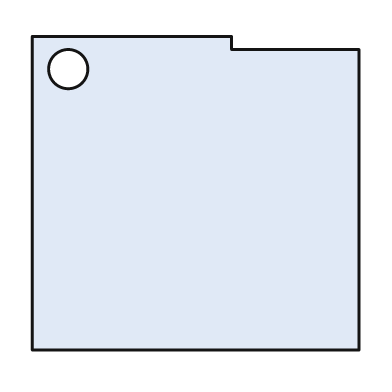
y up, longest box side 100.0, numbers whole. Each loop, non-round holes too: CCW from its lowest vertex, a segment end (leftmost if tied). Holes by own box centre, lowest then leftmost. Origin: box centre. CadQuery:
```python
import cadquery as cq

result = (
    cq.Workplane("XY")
    .moveTo(-50.0, -48.0)
    .lineTo(50.0, -48.0)
    .lineTo(50.0, 44.0)
    .lineTo(11.0, 44.0)
    .lineTo(11.0, 48.0)
    .lineTo(-50.0, 48.0)
    .close()
    .moveTo(-39.0, 38.0)
    .circle(6.0)
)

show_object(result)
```